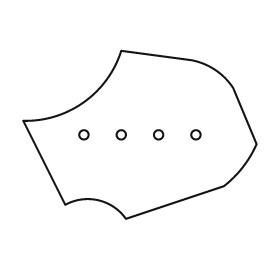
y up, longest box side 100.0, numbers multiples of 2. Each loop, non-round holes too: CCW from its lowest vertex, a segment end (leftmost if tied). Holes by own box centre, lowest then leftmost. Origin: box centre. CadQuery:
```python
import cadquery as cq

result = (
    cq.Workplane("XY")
    .moveTo(-6.0, -36.0)
    .lineTo(36.0, -22.0)
    .threePointArc((44.0, -14.0), (50.0, -4.0))
    .lineTo(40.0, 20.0)
    .threePointArc((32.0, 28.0), (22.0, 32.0))
    .lineTo(-8.0, 36.0)
    .threePointArc((-24.0, 14.0), (-50.0, 6.0))
    .lineTo(-32.0, -30.0)
    .threePointArc((-18.0, -28.0), (-6.0, -36.0))
    .close()
    .moveTo(-24.0, 0.0)
    .circle(2.0)
    .moveTo(-8.0, 0.0)
    .circle(2.0)
    .moveTo(8.0, 0.0)
    .circle(2.0)
    .moveTo(24.0, 0.0)
    .circle(2.0)
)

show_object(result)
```